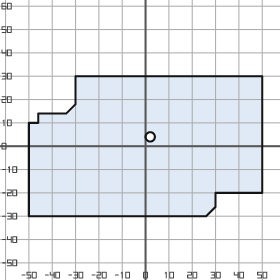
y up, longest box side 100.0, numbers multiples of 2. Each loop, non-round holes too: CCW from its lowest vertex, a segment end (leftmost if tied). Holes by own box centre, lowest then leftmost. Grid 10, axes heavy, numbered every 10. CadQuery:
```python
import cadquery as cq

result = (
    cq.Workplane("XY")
    .moveTo(-50.0, -30.0)
    .lineTo(26.0, -30.0)
    .lineTo(30.0, -26.0)
    .lineTo(30.0, -20.0)
    .lineTo(50.0, -20.0)
    .lineTo(50.0, 30.0)
    .lineTo(-30.0, 30.0)
    .lineTo(-30.0, 18.0)
    .lineTo(-34.0, 14.0)
    .lineTo(-46.0, 14.0)
    .lineTo(-46.0, 10.0)
    .lineTo(-50.0, 10.0)
    .close()
    .moveTo(2.0, 4.0)
    .circle(2.0)
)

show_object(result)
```